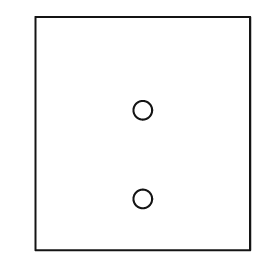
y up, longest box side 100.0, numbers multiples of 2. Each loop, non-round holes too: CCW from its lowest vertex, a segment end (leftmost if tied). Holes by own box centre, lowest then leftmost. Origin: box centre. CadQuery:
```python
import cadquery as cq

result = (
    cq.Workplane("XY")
    .moveTo(-46.0, -50.0)
    .lineTo(46.0, -50.0)
    .lineTo(46.0, 50.0)
    .lineTo(-46.0, 50.0)
    .close()
    .moveTo(0.0, -28.0)
    .circle(4.0)
    .moveTo(0.0, 10.0)
    .circle(4.0)
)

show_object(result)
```